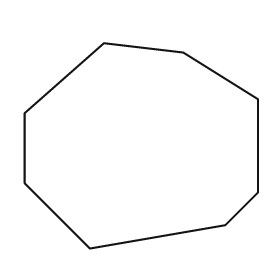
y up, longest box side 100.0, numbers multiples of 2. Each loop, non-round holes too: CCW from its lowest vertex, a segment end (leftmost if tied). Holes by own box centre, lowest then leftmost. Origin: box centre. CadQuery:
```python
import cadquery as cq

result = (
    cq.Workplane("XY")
    .moveTo(-22.0, -44.0)
    .lineTo(36.0, -34.0)
    .lineTo(50.0, -20.0)
    .lineTo(50.0, 20.0)
    .lineTo(18.0, 40.0)
    .lineTo(-16.0, 44.0)
    .lineTo(-50.0, 14.0)
    .lineTo(-50.0, -16.0)
    .close()
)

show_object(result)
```